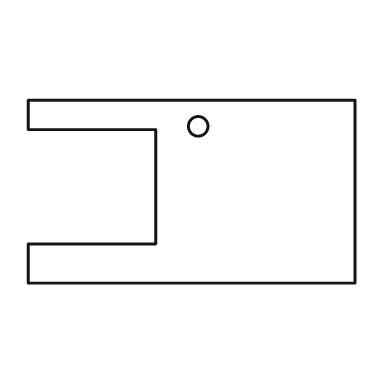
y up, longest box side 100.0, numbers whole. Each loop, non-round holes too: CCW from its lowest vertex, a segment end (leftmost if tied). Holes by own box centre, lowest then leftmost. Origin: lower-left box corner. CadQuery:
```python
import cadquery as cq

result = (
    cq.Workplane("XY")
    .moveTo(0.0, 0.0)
    .lineTo(100.0, 0.0)
    .lineTo(100.0, 56.0)
    .lineTo(0.0, 56.0)
    .lineTo(0.0, 47.0)
    .lineTo(39.0, 47.0)
    .lineTo(39.0, 12.0)
    .lineTo(0.0, 12.0)
    .close()
    .moveTo(52.0, 48.0)
    .circle(3.0)
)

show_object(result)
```